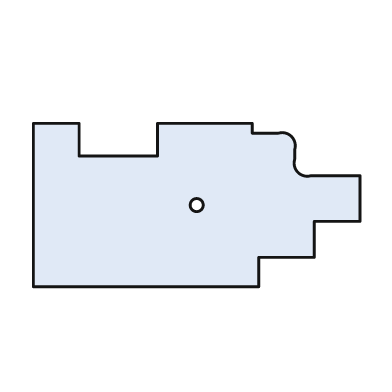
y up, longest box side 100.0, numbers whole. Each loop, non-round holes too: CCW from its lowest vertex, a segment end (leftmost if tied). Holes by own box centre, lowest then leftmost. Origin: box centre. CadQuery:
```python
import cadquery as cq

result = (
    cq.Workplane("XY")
    .moveTo(-50.0, -25.0)
    .lineTo(19.0, -25.0)
    .lineTo(19.0, -16.0)
    .lineTo(36.0, -16.0)
    .lineTo(36.0, -5.0)
    .lineTo(50.0, -5.0)
    .lineTo(50.0, 9.0)
    .lineTo(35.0, 9.0)
    .threePointArc((31.0, 10.0), (30.0, 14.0))
    .lineTo(30.0, 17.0)
    .threePointArc((29.0, 21.0), (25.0, 22.0))
    .lineTo(17.0, 22.0)
    .lineTo(17.0, 25.0)
    .lineTo(-12.0, 25.0)
    .lineTo(-12.0, 15.0)
    .lineTo(-36.0, 15.0)
    .lineTo(-36.0, 25.0)
    .lineTo(-50.0, 25.0)
    .close()
    .moveTo(0.0, 0.0)
    .circle(2.0)
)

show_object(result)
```